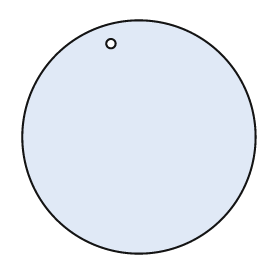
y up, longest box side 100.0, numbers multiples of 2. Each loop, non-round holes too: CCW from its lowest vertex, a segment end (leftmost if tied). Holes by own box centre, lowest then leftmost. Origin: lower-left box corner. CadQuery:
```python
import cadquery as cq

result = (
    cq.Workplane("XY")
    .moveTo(50.0, 50.0)
    .circle(50.0)
    .moveTo(38.0, 90.0)
    .circle(2.0)
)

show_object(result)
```